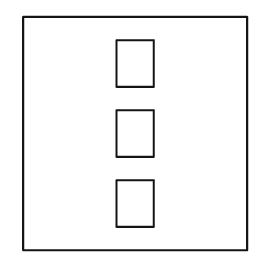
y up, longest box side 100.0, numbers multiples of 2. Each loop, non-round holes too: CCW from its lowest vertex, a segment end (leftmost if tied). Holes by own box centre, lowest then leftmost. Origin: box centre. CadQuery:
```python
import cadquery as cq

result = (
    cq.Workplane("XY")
    .moveTo(-48.0, -50.0)
    .lineTo(48.0, -50.0)
    .lineTo(48.0, 50.0)
    .lineTo(-48.0, 50.0)
    .close()
    .moveTo(-8.0, -40.0)
    .lineTo(8.0, -40.0)
    .lineTo(8.0, -20.0)
    .lineTo(-8.0, -20.0)
    .close()
    .moveTo(-8.0, -10.0)
    .lineTo(8.0, -10.0)
    .lineTo(8.0, 10.0)
    .lineTo(-8.0, 10.0)
    .close()
    .moveTo(-8.0, 20.0)
    .lineTo(8.0, 20.0)
    .lineTo(8.0, 40.0)
    .lineTo(-8.0, 40.0)
    .close()
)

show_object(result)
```